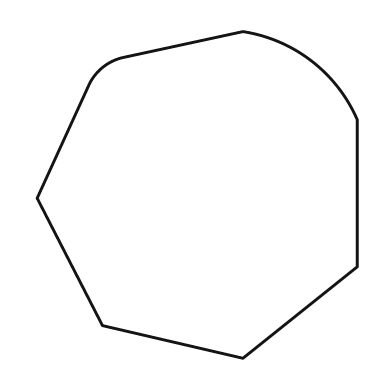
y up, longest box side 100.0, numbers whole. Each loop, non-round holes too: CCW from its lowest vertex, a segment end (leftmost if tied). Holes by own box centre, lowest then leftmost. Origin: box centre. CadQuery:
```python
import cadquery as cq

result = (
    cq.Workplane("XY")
    .moveTo(14.0, -50.0)
    .lineTo(49.0, -22.0)
    .lineTo(49.0, 23.0)
    .threePointArc((35.0, 41.0), (14.0, 50.0))
    .lineTo(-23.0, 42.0)
    .threePointArc((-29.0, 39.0), (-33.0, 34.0))
    .lineTo(-49.0, -1.0)
    .lineTo(-29.0, -40.0)
    .close()
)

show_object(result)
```